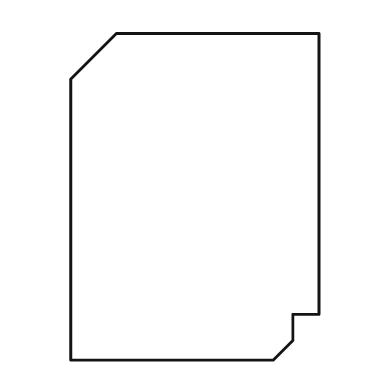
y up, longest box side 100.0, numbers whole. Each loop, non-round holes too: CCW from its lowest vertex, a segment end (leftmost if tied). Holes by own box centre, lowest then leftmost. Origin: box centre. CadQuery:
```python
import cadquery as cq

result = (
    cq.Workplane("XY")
    .moveTo(-38.0, -50.0)
    .lineTo(24.0, -50.0)
    .lineTo(30.0, -44.0)
    .lineTo(30.0, -36.0)
    .lineTo(38.0, -36.0)
    .lineTo(38.0, 50.0)
    .lineTo(-24.0, 50.0)
    .lineTo(-38.0, 36.0)
    .close()
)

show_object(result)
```